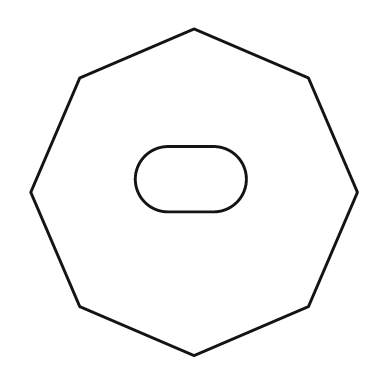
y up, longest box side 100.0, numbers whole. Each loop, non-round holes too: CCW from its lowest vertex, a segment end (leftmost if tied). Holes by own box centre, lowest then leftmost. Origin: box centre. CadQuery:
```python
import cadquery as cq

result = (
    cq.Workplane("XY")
    .moveTo(0.0, -50.0)
    .lineTo(35.0, -35.0)
    .lineTo(50.0, 0.0)
    .lineTo(35.0, 35.0)
    .lineTo(0.0, 50.0)
    .lineTo(-35.0, 35.0)
    .lineTo(-50.0, 0.0)
    .lineTo(-35.0, -35.0)
    .close()
    .moveTo(-8.0, -6.0)
    .lineTo(6.0, -6.0)
    .threePointArc((16.0, 4.0), (6.0, 14.0))
    .lineTo(-8.0, 14.0)
    .threePointArc((-18.0, 4.0), (-8.0, -6.0))
    .close()
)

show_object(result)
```